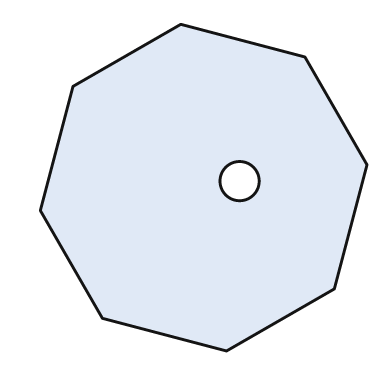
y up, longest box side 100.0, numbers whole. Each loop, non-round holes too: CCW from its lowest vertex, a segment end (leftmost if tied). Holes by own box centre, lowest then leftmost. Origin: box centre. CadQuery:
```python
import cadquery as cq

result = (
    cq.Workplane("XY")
    .moveTo(7.0, -50.0)
    .lineTo(40.0, -31.0)
    .lineTo(50.0, 7.0)
    .lineTo(31.0, 40.0)
    .lineTo(-7.0, 50.0)
    .lineTo(-40.0, 31.0)
    .lineTo(-50.0, -7.0)
    .lineTo(-31.0, -40.0)
    .close()
    .moveTo(11.0, 2.0)
    .circle(6.0)
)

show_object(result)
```